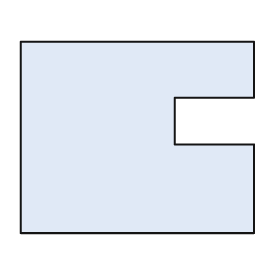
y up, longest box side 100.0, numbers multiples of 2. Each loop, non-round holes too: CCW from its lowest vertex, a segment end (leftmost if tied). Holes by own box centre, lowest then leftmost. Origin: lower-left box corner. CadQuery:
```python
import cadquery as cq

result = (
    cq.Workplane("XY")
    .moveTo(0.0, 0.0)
    .lineTo(100.0, 0.0)
    .lineTo(100.0, 38.0)
    .lineTo(66.0, 38.0)
    .lineTo(66.0, 58.0)
    .lineTo(100.0, 58.0)
    .lineTo(100.0, 82.0)
    .lineTo(0.0, 82.0)
    .close()
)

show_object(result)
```